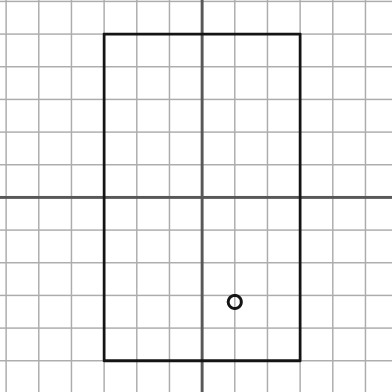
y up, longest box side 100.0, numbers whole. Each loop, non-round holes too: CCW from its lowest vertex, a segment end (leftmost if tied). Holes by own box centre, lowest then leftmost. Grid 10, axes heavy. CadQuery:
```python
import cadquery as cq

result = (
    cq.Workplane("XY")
    .moveTo(-30.0, -50.0)
    .lineTo(30.0, -50.0)
    .lineTo(30.0, 50.0)
    .lineTo(-30.0, 50.0)
    .close()
    .moveTo(10.0, -32.0)
    .circle(2.0)
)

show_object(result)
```